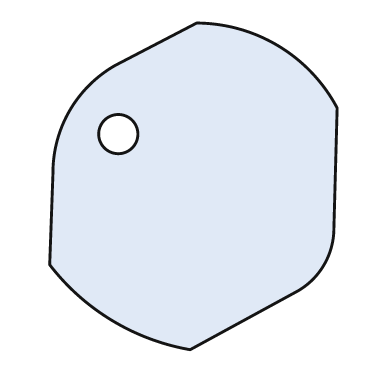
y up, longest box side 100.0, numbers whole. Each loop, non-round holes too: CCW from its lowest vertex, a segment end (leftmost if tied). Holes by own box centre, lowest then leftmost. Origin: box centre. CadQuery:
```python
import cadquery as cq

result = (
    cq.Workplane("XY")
    .moveTo(-1.0, -50.0)
    .lineTo(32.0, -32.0)
    .threePointArc((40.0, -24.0), (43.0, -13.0))
    .lineTo(44.0, 24.0)
    .threePointArc((26.0, 43.0), (1.0, 50.0))
    .lineTo(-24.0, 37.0)
    .threePointArc((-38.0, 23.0), (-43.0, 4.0))
    .lineTo(-44.0, -24.0)
    .threePointArc((-25.0, -41.0), (-1.0, -50.0))
    .close()
    .moveTo(-23.0, 16.0)
    .circle(6.0)
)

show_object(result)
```